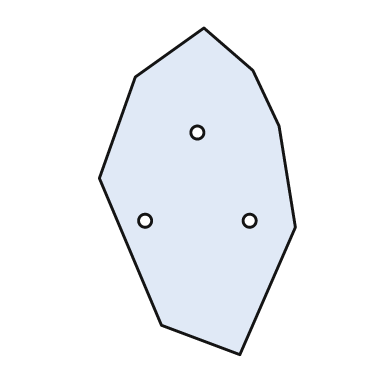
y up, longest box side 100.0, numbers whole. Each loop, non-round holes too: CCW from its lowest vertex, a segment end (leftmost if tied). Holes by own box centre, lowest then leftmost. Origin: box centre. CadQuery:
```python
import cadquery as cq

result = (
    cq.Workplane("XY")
    .moveTo(13.0, -50.0)
    .lineTo(30.0, -11.0)
    .lineTo(25.0, 20.0)
    .lineTo(17.0, 37.0)
    .lineTo(2.0, 50.0)
    .lineTo(-19.0, 35.0)
    .lineTo(-30.0, 4.0)
    .lineTo(-11.0, -41.0)
    .close()
    .moveTo(-16.0, -9.0)
    .circle(2.0)
    .moveTo(16.0, -9.0)
    .circle(2.0)
    .moveTo(0.0, 18.0)
    .circle(2.0)
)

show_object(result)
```